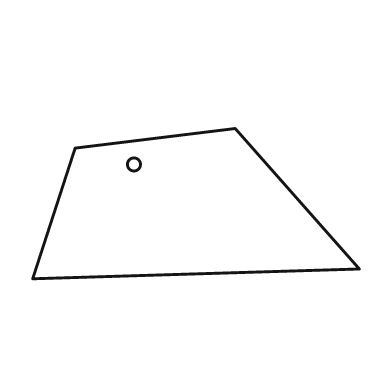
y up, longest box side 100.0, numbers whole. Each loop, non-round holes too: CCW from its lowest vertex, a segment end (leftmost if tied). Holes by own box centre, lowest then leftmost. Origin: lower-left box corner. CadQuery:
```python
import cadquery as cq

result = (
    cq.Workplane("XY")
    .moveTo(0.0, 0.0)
    .lineTo(100.0, 3.0)
    .lineTo(62.0, 46.0)
    .lineTo(13.0, 40.0)
    .close()
    .moveTo(31.0, 35.0)
    .circle(2.0)
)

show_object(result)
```